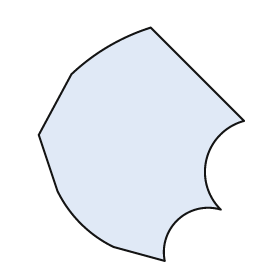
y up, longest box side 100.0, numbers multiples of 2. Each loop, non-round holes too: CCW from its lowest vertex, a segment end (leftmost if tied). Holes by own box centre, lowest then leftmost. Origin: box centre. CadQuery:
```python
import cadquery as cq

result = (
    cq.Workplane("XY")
    .moveTo(10.0, -50.0)
    .threePointArc((16.0, -32.0), (34.0, -28.0))
    .threePointArc((28.0, -6.0), (44.0, 10.0))
    .lineTo(4.0, 50.0)
    .threePointArc((-14.0, 42.0), (-30.0, 30.0))
    .lineTo(-44.0, 4.0)
    .lineTo(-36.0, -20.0)
    .threePointArc((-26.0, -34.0), (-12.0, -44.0))
    .close()
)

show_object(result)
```